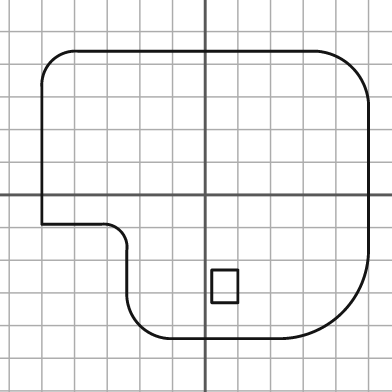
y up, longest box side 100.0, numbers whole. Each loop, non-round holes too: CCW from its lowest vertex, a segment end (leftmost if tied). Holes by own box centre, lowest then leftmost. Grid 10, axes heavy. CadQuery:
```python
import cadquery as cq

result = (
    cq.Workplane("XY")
    .moveTo(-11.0, -44.0)
    .lineTo(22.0, -44.0)
    .threePointArc((42.0, -36.0), (50.0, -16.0))
    .lineTo(50.0, 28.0)
    .threePointArc((45.0, 39.0), (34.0, 44.0))
    .lineTo(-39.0, 44.0)
    .threePointArc((-47.0, 41.0), (-50.0, 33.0))
    .lineTo(-50.0, -9.0)
    .lineTo(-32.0, -9.0)
    .threePointArc((-26.0, -11.0), (-24.0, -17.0))
    .lineTo(-24.0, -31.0)
    .threePointArc((-20.0, -40.0), (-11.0, -44.0))
    .close()
    .moveTo(2.0, -33.0)
    .lineTo(10.0, -33.0)
    .lineTo(10.0, -23.0)
    .lineTo(2.0, -23.0)
    .close()
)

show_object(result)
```